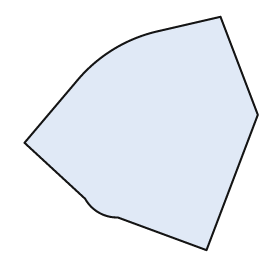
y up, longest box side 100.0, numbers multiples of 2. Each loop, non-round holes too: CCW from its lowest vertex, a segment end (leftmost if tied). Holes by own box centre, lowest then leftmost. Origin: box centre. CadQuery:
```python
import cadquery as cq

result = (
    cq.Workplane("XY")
    .moveTo(28.0, -50.0)
    .lineTo(50.0, 8.0)
    .lineTo(34.0, 50.0)
    .lineTo(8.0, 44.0)
    .threePointArc((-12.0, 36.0), (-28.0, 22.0))
    .lineTo(-50.0, -4.0)
    .lineTo(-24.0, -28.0)
    .threePointArc((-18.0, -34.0), (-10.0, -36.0))
    .close()
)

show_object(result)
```